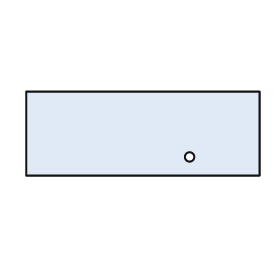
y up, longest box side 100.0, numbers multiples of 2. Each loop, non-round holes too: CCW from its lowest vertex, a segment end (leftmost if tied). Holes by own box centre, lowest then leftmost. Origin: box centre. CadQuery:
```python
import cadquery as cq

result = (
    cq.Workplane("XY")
    .moveTo(-50.0, -18.0)
    .lineTo(50.0, -18.0)
    .lineTo(50.0, 18.0)
    .lineTo(-50.0, 18.0)
    .close()
    .moveTo(20.0, -10.0)
    .circle(2.0)
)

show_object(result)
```